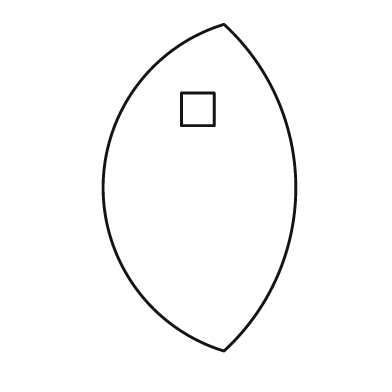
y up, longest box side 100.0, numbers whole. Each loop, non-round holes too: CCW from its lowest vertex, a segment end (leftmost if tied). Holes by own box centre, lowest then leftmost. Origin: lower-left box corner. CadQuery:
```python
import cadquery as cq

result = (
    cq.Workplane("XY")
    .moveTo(37.0, 0.0)
    .threePointArc((59.0, 50.0), (37.0, 100.0))
    .threePointArc((0.0, 50.0), (37.0, 0.0))
    .close()
    .moveTo(24.0, 69.0)
    .lineTo(34.0, 69.0)
    .lineTo(34.0, 79.0)
    .lineTo(24.0, 79.0)
    .close()
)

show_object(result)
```